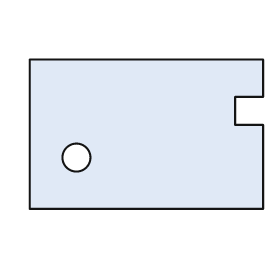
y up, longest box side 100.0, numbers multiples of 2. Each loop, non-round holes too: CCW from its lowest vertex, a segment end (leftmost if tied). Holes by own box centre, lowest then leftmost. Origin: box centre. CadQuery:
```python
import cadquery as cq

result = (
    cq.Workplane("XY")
    .moveTo(-50.0, -32.0)
    .lineTo(50.0, -32.0)
    .lineTo(50.0, 4.0)
    .lineTo(38.0, 4.0)
    .lineTo(38.0, 16.0)
    .lineTo(50.0, 16.0)
    .lineTo(50.0, 32.0)
    .lineTo(-50.0, 32.0)
    .close()
    .moveTo(-30.0, -10.0)
    .circle(6.0)
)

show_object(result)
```